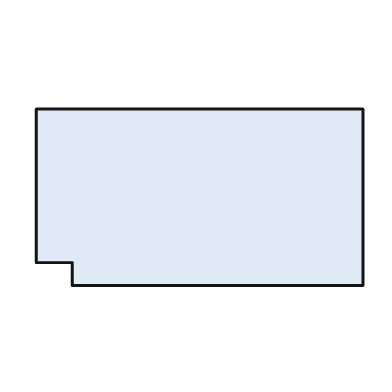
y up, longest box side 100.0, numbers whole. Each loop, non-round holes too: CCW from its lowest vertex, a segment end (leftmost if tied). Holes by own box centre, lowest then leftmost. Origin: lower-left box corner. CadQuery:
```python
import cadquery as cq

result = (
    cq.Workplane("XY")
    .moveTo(11.0, 0.0)
    .lineTo(100.0, 0.0)
    .lineTo(100.0, 54.0)
    .lineTo(0.0, 54.0)
    .lineTo(0.0, 7.0)
    .lineTo(11.0, 7.0)
    .close()
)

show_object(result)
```